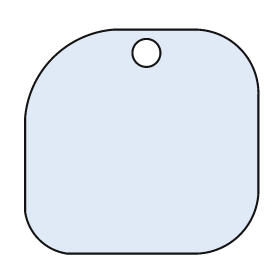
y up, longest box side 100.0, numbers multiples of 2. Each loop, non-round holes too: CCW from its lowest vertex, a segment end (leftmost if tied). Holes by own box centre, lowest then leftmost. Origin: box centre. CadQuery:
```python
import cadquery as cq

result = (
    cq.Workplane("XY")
    .moveTo(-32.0, -48.0)
    .lineTo(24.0, -48.0)
    .threePointArc((42.0, -40.0), (50.0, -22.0))
    .lineTo(50.0, 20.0)
    .threePointArc((42.0, 40.0), (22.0, 48.0))
    .lineTo(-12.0, 48.0)
    .threePointArc((-38.0, 36.0), (-50.0, 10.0))
    .lineTo(-50.0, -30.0)
    .threePointArc((-44.0, -42.0), (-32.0, -48.0))
    .close()
    .moveTo(2.0, 38.0)
    .circle(6.0)
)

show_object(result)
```